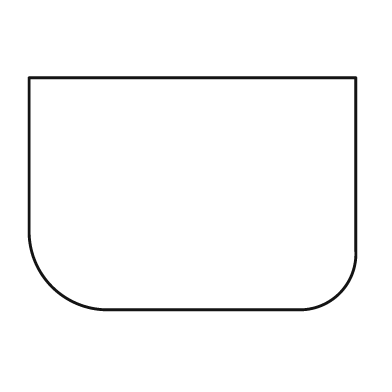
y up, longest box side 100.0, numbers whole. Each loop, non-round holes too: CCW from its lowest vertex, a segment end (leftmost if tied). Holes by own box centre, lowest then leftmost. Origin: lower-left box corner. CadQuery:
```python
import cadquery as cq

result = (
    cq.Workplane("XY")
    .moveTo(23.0, 0.0)
    .lineTo(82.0, 0.0)
    .threePointArc((95.0, 5.0), (100.0, 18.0))
    .lineTo(100.0, 71.0)
    .lineTo(0.0, 71.0)
    .lineTo(0.0, 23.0)
    .threePointArc((7.0, 7.0), (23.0, 0.0))
    .close()
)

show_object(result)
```